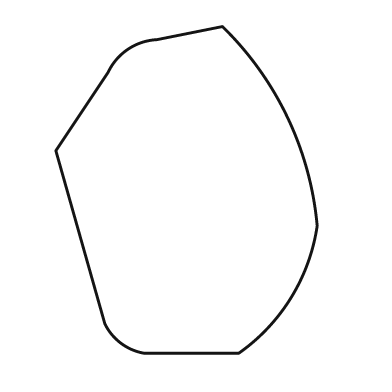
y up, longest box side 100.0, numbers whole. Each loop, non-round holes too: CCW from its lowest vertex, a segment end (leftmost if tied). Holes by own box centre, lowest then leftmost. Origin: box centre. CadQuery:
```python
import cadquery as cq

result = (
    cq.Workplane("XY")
    .moveTo(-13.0, -50.0)
    .lineTo(16.0, -50.0)
    .threePointArc((32.0, -33.0), (40.0, -11.0))
    .threePointArc((31.0, 22.0), (11.0, 50.0))
    .lineTo(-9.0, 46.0)
    .threePointArc((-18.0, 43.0), (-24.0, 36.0))
    .lineTo(-40.0, 12.0)
    .lineTo(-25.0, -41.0)
    .threePointArc((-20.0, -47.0), (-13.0, -50.0))
    .close()
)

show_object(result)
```